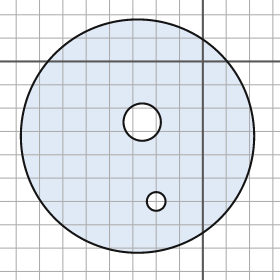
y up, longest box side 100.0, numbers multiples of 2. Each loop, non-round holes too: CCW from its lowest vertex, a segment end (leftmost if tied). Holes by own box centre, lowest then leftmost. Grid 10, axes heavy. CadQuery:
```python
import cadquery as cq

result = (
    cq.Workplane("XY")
    .moveTo(-28.0, -32.0)
    .circle(50.0)
    .moveTo(-20.0, -60.0)
    .circle(4.0)
    .moveTo(-26.0, -26.0)
    .circle(8.0)
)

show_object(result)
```